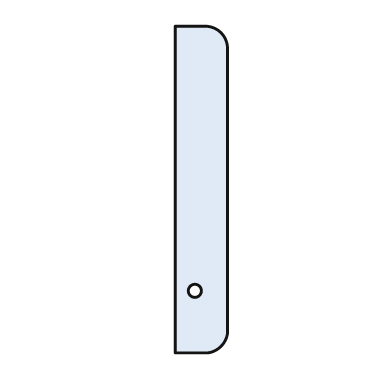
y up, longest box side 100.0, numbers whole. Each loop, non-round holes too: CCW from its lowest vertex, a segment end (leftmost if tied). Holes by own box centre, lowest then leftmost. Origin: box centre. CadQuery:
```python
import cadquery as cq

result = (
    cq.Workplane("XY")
    .moveTo(-8.0, -50.0)
    .lineTo(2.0, -50.0)
    .threePointArc((6.0, -48.0), (8.0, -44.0))
    .lineTo(8.0, 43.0)
    .threePointArc((6.0, 48.0), (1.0, 50.0))
    .lineTo(-8.0, 50.0)
    .close()
    .moveTo(-2.0, -31.0)
    .circle(2.0)
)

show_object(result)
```